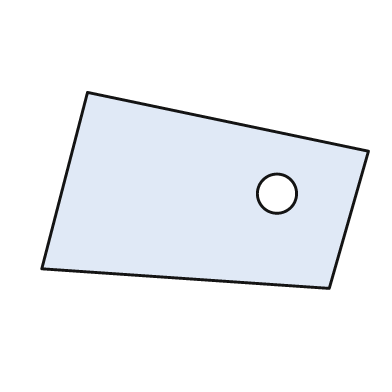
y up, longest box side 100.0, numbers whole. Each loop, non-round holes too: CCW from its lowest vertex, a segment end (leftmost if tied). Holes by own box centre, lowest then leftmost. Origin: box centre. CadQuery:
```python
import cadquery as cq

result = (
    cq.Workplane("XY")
    .moveTo(38.0, -30.0)
    .lineTo(50.0, 12.0)
    .lineTo(-36.0, 30.0)
    .lineTo(-50.0, -24.0)
    .close()
    .moveTo(22.0, -1.0)
    .circle(6.0)
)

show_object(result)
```